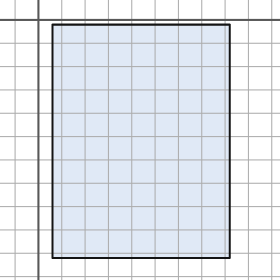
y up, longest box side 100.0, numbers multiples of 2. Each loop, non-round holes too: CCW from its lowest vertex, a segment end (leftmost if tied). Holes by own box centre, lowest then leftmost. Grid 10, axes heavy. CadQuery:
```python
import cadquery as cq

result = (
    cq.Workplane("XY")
    .moveTo(6.0, -102.0)
    .lineTo(82.0, -102.0)
    .lineTo(82.0, -2.0)
    .lineTo(6.0, -2.0)
    .close()
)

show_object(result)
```